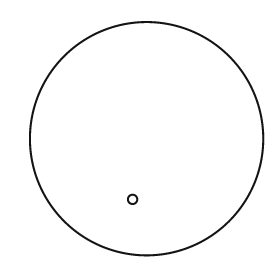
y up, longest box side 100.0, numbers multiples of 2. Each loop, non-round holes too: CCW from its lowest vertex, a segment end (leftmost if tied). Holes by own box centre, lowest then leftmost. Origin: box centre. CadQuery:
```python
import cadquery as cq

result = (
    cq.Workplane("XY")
    .moveTo(0.0, 0.0)
    .circle(50.0)
    .moveTo(-6.0, -26.0)
    .circle(2.0)
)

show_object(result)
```